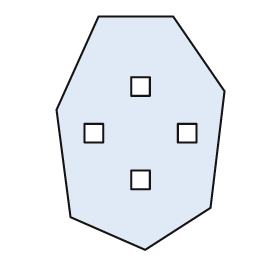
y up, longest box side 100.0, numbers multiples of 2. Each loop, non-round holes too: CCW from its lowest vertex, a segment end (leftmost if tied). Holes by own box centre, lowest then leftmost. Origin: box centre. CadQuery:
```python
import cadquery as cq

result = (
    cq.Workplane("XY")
    .moveTo(2.0, -50.0)
    .lineTo(30.0, -32.0)
    .lineTo(36.0, 18.0)
    .lineTo(14.0, 50.0)
    .lineTo(-18.0, 50.0)
    .lineTo(-36.0, 10.0)
    .lineTo(-30.0, -36.0)
    .close()
    .moveTo(-4.0, -24.0)
    .lineTo(4.0, -24.0)
    .lineTo(4.0, -16.0)
    .lineTo(-4.0, -16.0)
    .close()
    .moveTo(-24.0, -4.0)
    .lineTo(-16.0, -4.0)
    .lineTo(-16.0, 4.0)
    .lineTo(-24.0, 4.0)
    .close()
    .moveTo(16.0, -4.0)
    .lineTo(24.0, -4.0)
    .lineTo(24.0, 4.0)
    .lineTo(16.0, 4.0)
    .close()
    .moveTo(-4.0, 16.0)
    .lineTo(4.0, 16.0)
    .lineTo(4.0, 24.0)
    .lineTo(-4.0, 24.0)
    .close()
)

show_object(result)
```